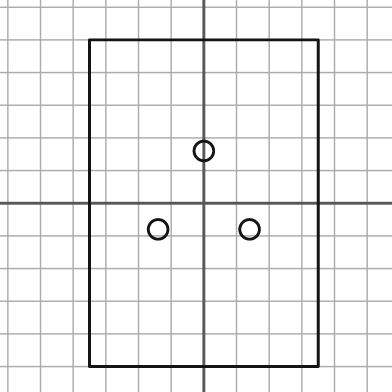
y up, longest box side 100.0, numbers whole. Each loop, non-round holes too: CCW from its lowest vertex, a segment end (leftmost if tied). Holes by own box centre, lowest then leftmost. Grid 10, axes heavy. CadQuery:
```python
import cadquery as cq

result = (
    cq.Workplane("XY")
    .moveTo(-35.0, -50.0)
    .lineTo(35.0, -50.0)
    .lineTo(35.0, 50.0)
    .lineTo(-35.0, 50.0)
    .close()
    .moveTo(-14.0, -8.0)
    .circle(3.0)
    .moveTo(14.0, -8.0)
    .circle(3.0)
    .moveTo(0.0, 16.0)
    .circle(3.0)
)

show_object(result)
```